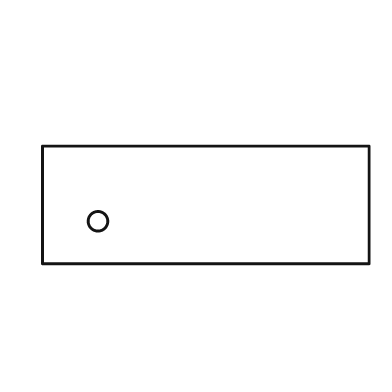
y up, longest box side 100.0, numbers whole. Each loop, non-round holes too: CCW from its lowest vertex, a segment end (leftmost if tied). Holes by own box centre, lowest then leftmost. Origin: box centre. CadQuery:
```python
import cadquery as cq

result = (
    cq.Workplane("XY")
    .moveTo(-50.0, -18.0)
    .lineTo(50.0, -18.0)
    .lineTo(50.0, 18.0)
    .lineTo(-50.0, 18.0)
    .close()
    .moveTo(-33.0, -5.0)
    .circle(3.0)
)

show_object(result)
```